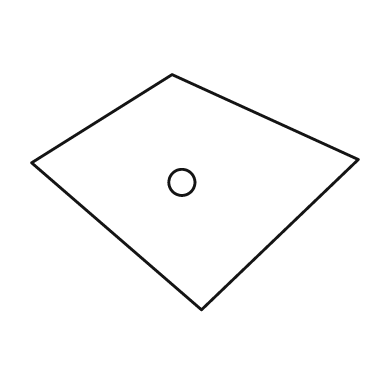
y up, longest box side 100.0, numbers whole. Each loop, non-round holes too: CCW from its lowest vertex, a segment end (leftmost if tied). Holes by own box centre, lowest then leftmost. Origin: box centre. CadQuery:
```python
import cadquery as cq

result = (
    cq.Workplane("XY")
    .moveTo(2.0, -36.0)
    .lineTo(50.0, 10.0)
    .lineTo(-7.0, 36.0)
    .lineTo(-50.0, 9.0)
    .close()
    .moveTo(-4.0, 3.0)
    .circle(4.0)
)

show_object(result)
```